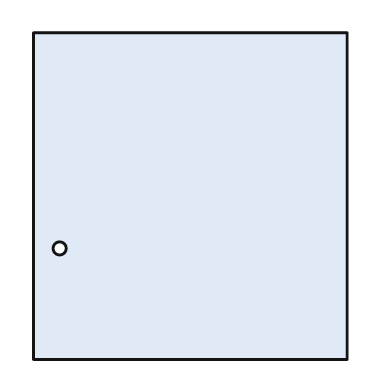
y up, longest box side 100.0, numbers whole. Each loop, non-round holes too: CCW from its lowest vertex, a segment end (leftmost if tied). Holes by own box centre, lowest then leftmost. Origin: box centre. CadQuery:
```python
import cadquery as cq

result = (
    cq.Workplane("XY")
    .moveTo(-48.0, -50.0)
    .lineTo(48.0, -50.0)
    .lineTo(48.0, 50.0)
    .lineTo(-48.0, 50.0)
    .close()
    .moveTo(-40.0, -16.0)
    .circle(2.0)
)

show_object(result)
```